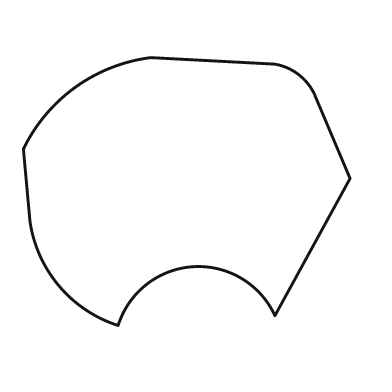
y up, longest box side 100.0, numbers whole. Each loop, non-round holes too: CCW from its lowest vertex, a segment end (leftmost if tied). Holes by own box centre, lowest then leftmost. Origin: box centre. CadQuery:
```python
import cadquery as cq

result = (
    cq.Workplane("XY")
    .moveTo(-21.0, -41.0)
    .threePointArc((2.0, -23.0), (27.0, -38.0))
    .lineTo(50.0, 4.0)
    .lineTo(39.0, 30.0)
    .threePointArc((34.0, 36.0), (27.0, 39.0))
    .lineTo(-11.0, 41.0)
    .threePointArc((-34.0, 32.0), (-50.0, 13.0))
    .lineTo(-48.0, -9.0)
    .threePointArc((-39.0, -29.0), (-21.0, -41.0))
    .close()
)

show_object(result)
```